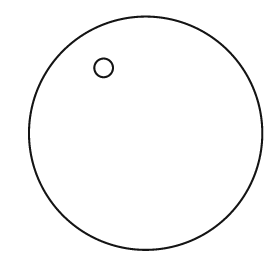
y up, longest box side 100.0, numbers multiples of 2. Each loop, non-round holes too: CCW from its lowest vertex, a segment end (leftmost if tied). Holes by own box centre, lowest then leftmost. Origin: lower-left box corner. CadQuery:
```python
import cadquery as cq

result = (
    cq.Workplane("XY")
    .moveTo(50.0, 50.0)
    .circle(50.0)
    .moveTo(32.0, 78.0)
    .circle(4.0)
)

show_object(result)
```